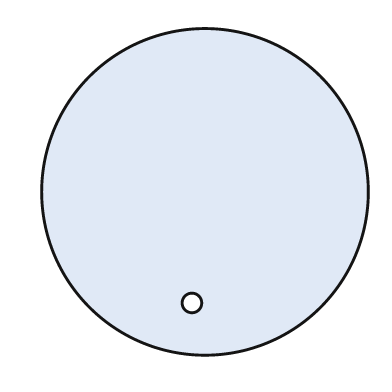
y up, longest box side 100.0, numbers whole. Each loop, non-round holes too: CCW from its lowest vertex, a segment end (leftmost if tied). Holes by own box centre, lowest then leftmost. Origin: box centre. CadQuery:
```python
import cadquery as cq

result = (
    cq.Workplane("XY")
    .moveTo(0.0, 0.0)
    .circle(50.0)
    .moveTo(-4.0, -34.0)
    .circle(3.0)
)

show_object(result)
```